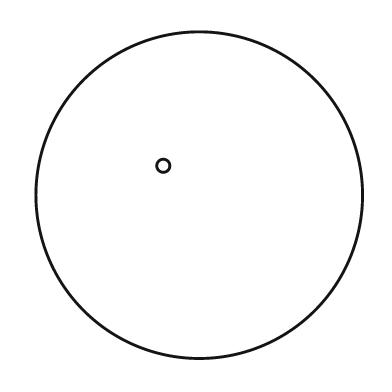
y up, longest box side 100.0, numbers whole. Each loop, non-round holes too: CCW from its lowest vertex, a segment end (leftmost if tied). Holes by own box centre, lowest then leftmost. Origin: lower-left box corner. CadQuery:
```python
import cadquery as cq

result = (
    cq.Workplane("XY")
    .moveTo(50.0, 50.0)
    .circle(50.0)
    .moveTo(39.0, 59.0)
    .circle(2.0)
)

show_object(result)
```